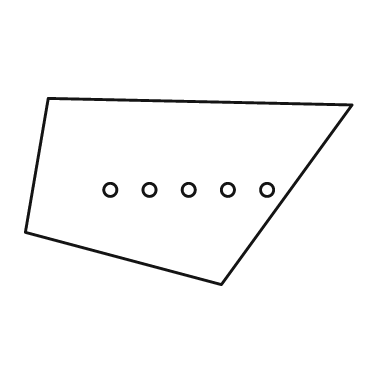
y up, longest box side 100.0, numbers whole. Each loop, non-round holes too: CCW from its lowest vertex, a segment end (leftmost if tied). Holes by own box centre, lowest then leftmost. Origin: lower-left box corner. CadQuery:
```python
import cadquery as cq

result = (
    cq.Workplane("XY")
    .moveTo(60.0, 0.0)
    .lineTo(100.0, 55.0)
    .lineTo(7.0, 57.0)
    .lineTo(0.0, 16.0)
    .close()
    .moveTo(26.0, 29.0)
    .circle(2.0)
    .moveTo(38.0, 29.0)
    .circle(2.0)
    .moveTo(50.0, 29.0)
    .circle(2.0)
    .moveTo(62.0, 29.0)
    .circle(2.0)
    .moveTo(74.0, 29.0)
    .circle(2.0)
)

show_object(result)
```